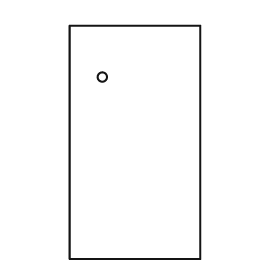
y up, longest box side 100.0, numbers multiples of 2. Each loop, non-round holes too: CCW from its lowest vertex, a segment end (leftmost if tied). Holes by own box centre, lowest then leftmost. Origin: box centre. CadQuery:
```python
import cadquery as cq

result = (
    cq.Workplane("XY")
    .moveTo(-28.0, -50.0)
    .lineTo(28.0, -50.0)
    .lineTo(28.0, 50.0)
    .lineTo(-28.0, 50.0)
    .close()
    .moveTo(-14.0, 28.0)
    .circle(2.0)
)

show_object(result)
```